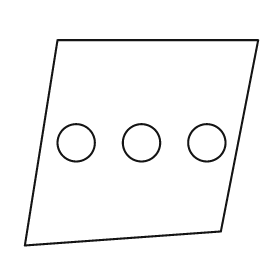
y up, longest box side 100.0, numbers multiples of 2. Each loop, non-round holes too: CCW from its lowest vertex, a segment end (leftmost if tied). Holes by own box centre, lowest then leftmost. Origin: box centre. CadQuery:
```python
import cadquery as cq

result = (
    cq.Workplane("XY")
    .moveTo(-50.0, -44.0)
    .lineTo(34.0, -38.0)
    .lineTo(50.0, 44.0)
    .lineTo(-36.0, 44.0)
    .close()
    .moveTo(-28.0, 0.0)
    .circle(8.0)
    .moveTo(0.0, 0.0)
    .circle(8.0)
    .moveTo(28.0, 0.0)
    .circle(8.0)
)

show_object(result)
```